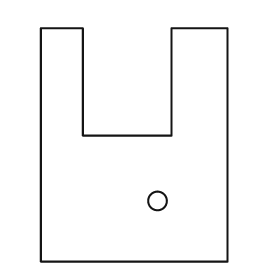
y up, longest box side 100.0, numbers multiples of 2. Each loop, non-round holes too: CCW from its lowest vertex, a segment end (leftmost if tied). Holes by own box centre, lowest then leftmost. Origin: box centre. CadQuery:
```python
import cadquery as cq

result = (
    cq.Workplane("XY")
    .moveTo(-40.0, -50.0)
    .lineTo(40.0, -50.0)
    .lineTo(40.0, 50.0)
    .lineTo(16.0, 50.0)
    .lineTo(16.0, 4.0)
    .lineTo(-22.0, 4.0)
    .lineTo(-22.0, 50.0)
    .lineTo(-40.0, 50.0)
    .close()
    .moveTo(10.0, -24.0)
    .circle(4.0)
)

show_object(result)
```